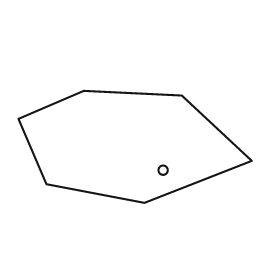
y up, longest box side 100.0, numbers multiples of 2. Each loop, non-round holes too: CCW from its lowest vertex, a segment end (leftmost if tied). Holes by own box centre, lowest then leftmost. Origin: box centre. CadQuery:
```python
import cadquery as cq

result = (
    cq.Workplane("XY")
    .moveTo(4.0, -24.0)
    .lineTo(50.0, -6.0)
    .lineTo(20.0, 22.0)
    .lineTo(-22.0, 24.0)
    .lineTo(-50.0, 12.0)
    .lineTo(-38.0, -16.0)
    .close()
    .moveTo(12.0, -10.0)
    .circle(2.0)
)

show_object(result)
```